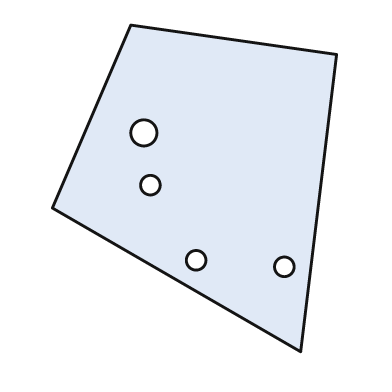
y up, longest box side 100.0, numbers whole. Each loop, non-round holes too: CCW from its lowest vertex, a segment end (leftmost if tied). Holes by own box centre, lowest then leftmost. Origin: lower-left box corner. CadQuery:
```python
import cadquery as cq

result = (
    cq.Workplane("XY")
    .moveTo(76.0, 0.0)
    .lineTo(87.0, 91.0)
    .lineTo(24.0, 100.0)
    .lineTo(0.0, 44.0)
    .close()
    .moveTo(71.0, 26.0)
    .circle(3.0)
    .moveTo(44.0, 28.0)
    .circle(3.0)
    .moveTo(30.0, 51.0)
    .circle(3.0)
    .moveTo(28.0, 67.0)
    .circle(4.0)
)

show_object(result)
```